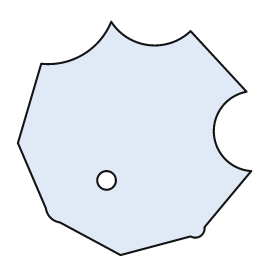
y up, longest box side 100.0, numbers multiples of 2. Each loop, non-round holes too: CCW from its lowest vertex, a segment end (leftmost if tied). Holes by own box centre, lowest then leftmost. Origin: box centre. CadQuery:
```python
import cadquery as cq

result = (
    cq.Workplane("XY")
    .moveTo(-6.0, -50.0)
    .lineTo(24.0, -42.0)
    .threePointArc((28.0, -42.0), (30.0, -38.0))
    .lineTo(50.0, -14.0)
    .threePointArc((34.0, 2.0), (48.0, 20.0))
    .lineTo(24.0, 46.0)
    .threePointArc((6.0, 40.0), (-10.0, 50.0))
    .threePointArc((-22.0, 36.0), (-40.0, 32.0))
    .lineTo(-50.0, -2.0)
    .lineTo(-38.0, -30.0)
    .threePointArc((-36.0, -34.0), (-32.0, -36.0))
    .close()
    .moveTo(-12.0, -18.0)
    .circle(4.0)
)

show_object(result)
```